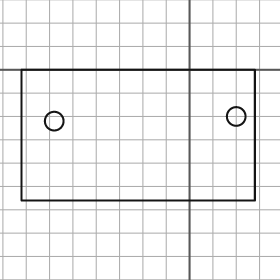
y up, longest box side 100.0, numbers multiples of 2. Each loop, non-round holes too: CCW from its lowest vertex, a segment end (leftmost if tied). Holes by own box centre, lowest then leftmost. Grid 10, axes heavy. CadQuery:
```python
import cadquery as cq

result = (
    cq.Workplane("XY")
    .moveTo(-72.0, -56.0)
    .lineTo(28.0, -56.0)
    .lineTo(28.0, 0.0)
    .lineTo(-72.0, 0.0)
    .close()
    .moveTo(-58.0, -22.0)
    .circle(4.0)
    .moveTo(20.0, -20.0)
    .circle(4.0)
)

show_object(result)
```